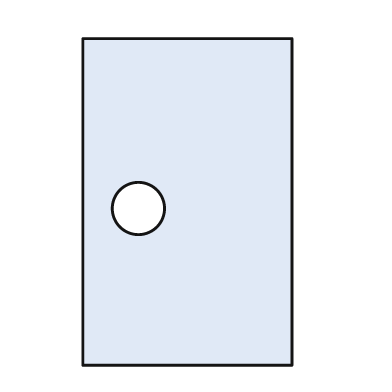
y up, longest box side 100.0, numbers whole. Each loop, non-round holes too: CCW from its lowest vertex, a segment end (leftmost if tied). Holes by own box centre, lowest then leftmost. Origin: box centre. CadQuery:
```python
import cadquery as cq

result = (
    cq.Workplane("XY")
    .moveTo(-32.0, -50.0)
    .lineTo(32.0, -50.0)
    .lineTo(32.0, 50.0)
    .lineTo(-32.0, 50.0)
    .close()
    .moveTo(-15.0, -2.0)
    .circle(8.0)
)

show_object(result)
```